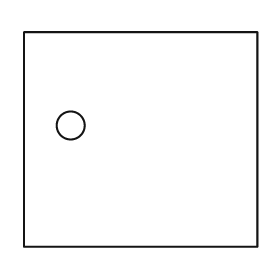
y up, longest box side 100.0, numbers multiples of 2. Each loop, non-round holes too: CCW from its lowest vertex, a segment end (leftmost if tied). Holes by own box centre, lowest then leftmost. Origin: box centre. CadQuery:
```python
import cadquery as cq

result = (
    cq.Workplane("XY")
    .moveTo(-50.0, -46.0)
    .lineTo(50.0, -46.0)
    .lineTo(50.0, 46.0)
    .lineTo(-50.0, 46.0)
    .close()
    .moveTo(-30.0, 6.0)
    .circle(6.0)
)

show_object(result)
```